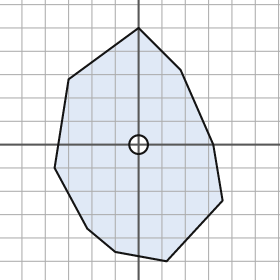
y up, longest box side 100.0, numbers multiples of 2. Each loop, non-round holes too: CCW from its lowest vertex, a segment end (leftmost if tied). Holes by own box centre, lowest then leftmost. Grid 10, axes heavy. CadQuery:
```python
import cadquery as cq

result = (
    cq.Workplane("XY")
    .moveTo(12.0, -50.0)
    .lineTo(36.0, -24.0)
    .lineTo(32.0, 0.0)
    .lineTo(18.0, 32.0)
    .lineTo(0.0, 50.0)
    .lineTo(-30.0, 28.0)
    .lineTo(-36.0, -10.0)
    .lineTo(-22.0, -36.0)
    .lineTo(-10.0, -46.0)
    .close()
    .moveTo(0.0, 0.0)
    .circle(4.0)
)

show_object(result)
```